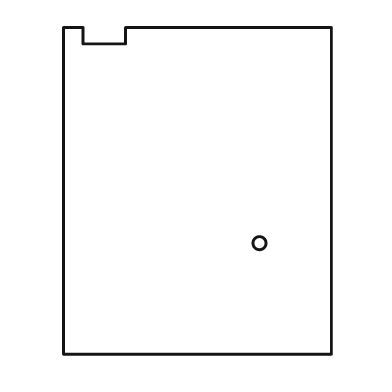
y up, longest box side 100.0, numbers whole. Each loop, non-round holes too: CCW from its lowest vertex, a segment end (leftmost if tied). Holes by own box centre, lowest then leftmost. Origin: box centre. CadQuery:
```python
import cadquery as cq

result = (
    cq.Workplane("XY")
    .moveTo(-41.0, -50.0)
    .lineTo(41.0, -50.0)
    .lineTo(41.0, 50.0)
    .lineTo(-22.0, 50.0)
    .lineTo(-22.0, 45.0)
    .lineTo(-35.0, 45.0)
    .lineTo(-35.0, 50.0)
    .lineTo(-41.0, 50.0)
    .close()
    .moveTo(19.0, -16.0)
    .circle(2.0)
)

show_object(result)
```